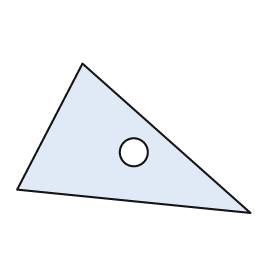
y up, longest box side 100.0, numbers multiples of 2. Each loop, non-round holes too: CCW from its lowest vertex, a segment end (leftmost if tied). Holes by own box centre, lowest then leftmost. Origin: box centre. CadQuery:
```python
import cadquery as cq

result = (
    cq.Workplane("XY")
    .moveTo(50.0, -32.0)
    .lineTo(-22.0, 32.0)
    .lineTo(-50.0, -22.0)
    .close()
    .moveTo(0.0, -6.0)
    .circle(6.0)
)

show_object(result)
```